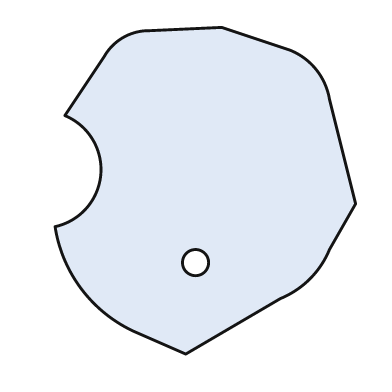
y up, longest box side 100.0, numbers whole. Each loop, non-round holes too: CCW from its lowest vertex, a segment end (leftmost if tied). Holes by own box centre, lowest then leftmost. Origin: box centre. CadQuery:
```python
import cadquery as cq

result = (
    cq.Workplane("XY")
    .moveTo(-6.0, -50.0)
    .lineTo(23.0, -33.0)
    .threePointArc((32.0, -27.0), (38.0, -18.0))
    .lineTo(46.0, -4.0)
    .lineTo(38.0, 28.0)
    .threePointArc((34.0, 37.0), (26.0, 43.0))
    .lineTo(5.0, 50.0)
    .lineTo(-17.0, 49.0)
    .threePointArc((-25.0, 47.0), (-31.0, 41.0))
    .lineTo(-43.0, 23.0)
    .threePointArc((-32.0, 5.0), (-46.0, -11.0))
    .threePointArc((-38.0, -30.0), (-22.0, -43.0))
    .close()
    .moveTo(-3.0, -22.0)
    .circle(4.0)
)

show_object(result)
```